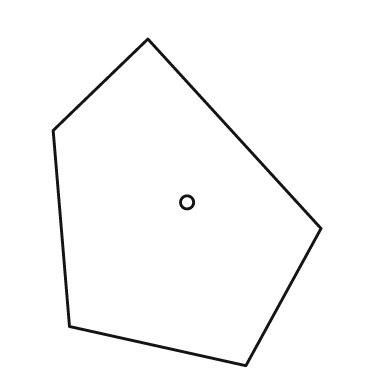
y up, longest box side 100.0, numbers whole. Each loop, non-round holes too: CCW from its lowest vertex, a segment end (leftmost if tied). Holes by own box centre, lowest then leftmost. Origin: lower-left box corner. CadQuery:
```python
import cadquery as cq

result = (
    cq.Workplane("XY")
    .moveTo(59.0, 0.0)
    .lineTo(82.0, 42.0)
    .lineTo(29.0, 100.0)
    .lineTo(0.0, 72.0)
    .lineTo(5.0, 12.0)
    .close()
    .moveTo(41.0, 50.0)
    .circle(2.0)
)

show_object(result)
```